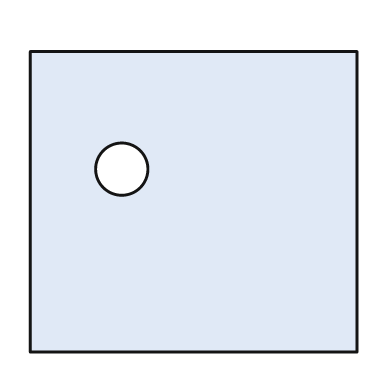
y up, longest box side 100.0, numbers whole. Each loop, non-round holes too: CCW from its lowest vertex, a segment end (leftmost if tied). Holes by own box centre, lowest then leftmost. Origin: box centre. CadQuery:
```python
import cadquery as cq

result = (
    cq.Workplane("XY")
    .moveTo(-50.0, -46.0)
    .lineTo(50.0, -46.0)
    .lineTo(50.0, 46.0)
    .lineTo(-50.0, 46.0)
    .close()
    .moveTo(-22.0, 10.0)
    .circle(8.0)
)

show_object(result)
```